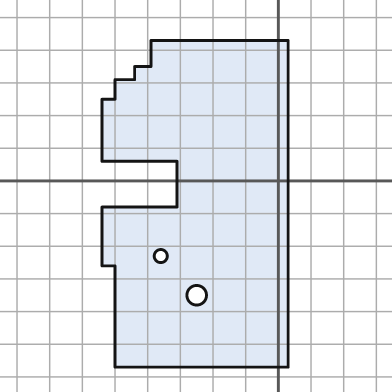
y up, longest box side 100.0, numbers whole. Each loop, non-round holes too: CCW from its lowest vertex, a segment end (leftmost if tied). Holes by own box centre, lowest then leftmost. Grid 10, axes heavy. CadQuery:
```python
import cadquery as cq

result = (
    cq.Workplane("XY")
    .moveTo(-50.0, -57.0)
    .lineTo(3.0, -57.0)
    .lineTo(3.0, 43.0)
    .lineTo(-39.0, 43.0)
    .lineTo(-39.0, 35.0)
    .lineTo(-44.0, 35.0)
    .lineTo(-44.0, 31.0)
    .lineTo(-50.0, 31.0)
    .lineTo(-50.0, 25.0)
    .lineTo(-54.0, 25.0)
    .lineTo(-54.0, 6.0)
    .lineTo(-31.0, 6.0)
    .lineTo(-31.0, -8.0)
    .lineTo(-54.0, -8.0)
    .lineTo(-54.0, -26.0)
    .lineTo(-50.0, -26.0)
    .close()
    .moveTo(-25.0, -35.0)
    .circle(3.0)
    .moveTo(-36.0, -23.0)
    .circle(2.0)
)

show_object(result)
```